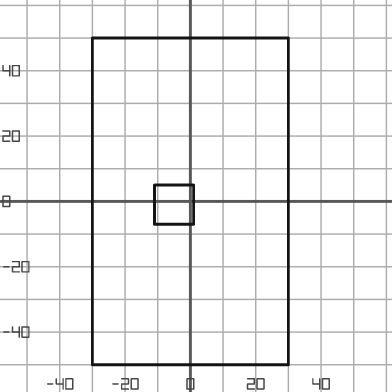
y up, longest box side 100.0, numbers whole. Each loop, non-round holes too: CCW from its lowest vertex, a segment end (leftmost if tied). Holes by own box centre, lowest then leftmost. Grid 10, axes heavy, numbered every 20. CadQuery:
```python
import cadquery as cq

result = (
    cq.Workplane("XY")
    .moveTo(-30.0, -50.0)
    .lineTo(30.0, -50.0)
    .lineTo(30.0, 50.0)
    .lineTo(-30.0, 50.0)
    .close()
    .moveTo(-11.0, -7.0)
    .lineTo(1.0, -7.0)
    .lineTo(1.0, 5.0)
    .lineTo(-11.0, 5.0)
    .close()
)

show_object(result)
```